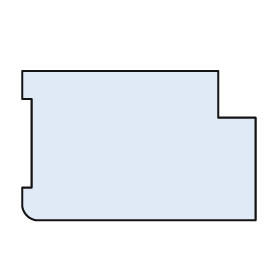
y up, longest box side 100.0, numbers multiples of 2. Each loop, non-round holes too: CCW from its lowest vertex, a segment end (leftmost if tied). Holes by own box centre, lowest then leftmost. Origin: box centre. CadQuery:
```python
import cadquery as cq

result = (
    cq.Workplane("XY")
    .moveTo(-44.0, -32.0)
    .lineTo(50.0, -32.0)
    .lineTo(50.0, 12.0)
    .lineTo(34.0, 12.0)
    .lineTo(34.0, 32.0)
    .lineTo(-50.0, 32.0)
    .lineTo(-50.0, 20.0)
    .lineTo(-46.0, 20.0)
    .lineTo(-46.0, -18.0)
    .lineTo(-50.0, -18.0)
    .lineTo(-50.0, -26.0)
    .threePointArc((-48.0, -30.0), (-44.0, -32.0))
    .close()
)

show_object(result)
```